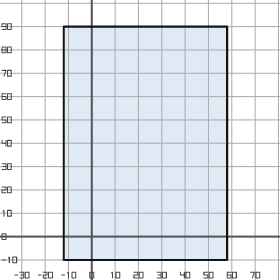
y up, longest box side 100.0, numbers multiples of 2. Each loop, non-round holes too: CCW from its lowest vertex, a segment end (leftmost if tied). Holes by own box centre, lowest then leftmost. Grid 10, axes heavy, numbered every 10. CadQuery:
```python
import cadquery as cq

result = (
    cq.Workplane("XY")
    .moveTo(-12.0, -10.0)
    .lineTo(58.0, -10.0)
    .lineTo(58.0, 90.0)
    .lineTo(-12.0, 90.0)
    .close()
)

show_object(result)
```